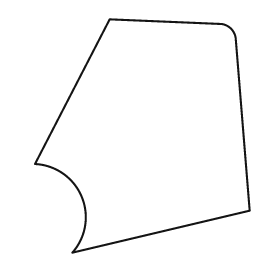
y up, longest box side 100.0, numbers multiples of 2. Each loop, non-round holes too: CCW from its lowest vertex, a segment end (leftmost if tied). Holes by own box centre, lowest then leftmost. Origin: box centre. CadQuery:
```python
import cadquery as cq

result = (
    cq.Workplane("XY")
    .moveTo(-30.0, -50.0)
    .lineTo(46.0, -32.0)
    .lineTo(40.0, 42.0)
    .threePointArc((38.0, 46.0), (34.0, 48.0))
    .lineTo(-14.0, 50.0)
    .lineTo(-46.0, -12.0)
    .threePointArc((-26.0, -26.0), (-30.0, -50.0))
    .close()
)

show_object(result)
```